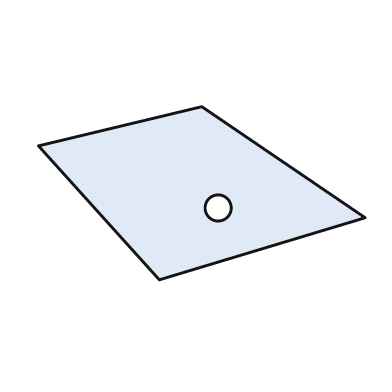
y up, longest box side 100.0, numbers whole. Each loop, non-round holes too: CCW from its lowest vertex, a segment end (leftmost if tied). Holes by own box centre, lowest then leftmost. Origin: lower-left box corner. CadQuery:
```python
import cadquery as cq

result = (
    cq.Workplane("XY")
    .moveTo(37.0, 0.0)
    .lineTo(100.0, 19.0)
    .lineTo(50.0, 53.0)
    .lineTo(0.0, 41.0)
    .close()
    .moveTo(55.0, 22.0)
    .circle(4.0)
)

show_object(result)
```